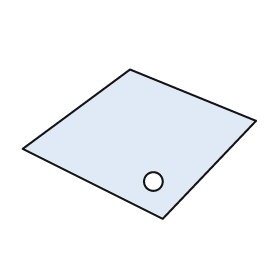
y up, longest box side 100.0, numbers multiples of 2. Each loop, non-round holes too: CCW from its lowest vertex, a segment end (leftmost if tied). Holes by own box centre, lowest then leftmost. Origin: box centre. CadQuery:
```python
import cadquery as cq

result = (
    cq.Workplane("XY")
    .moveTo(10.0, -32.0)
    .lineTo(50.0, 10.0)
    .lineTo(-4.0, 32.0)
    .lineTo(-50.0, -2.0)
    .close()
    .moveTo(6.0, -16.0)
    .circle(4.0)
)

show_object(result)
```